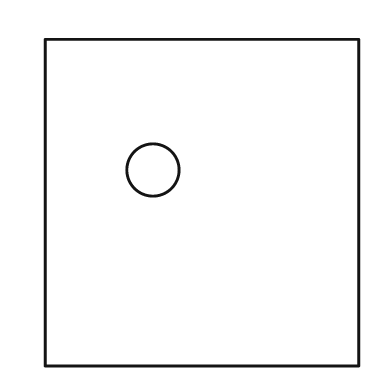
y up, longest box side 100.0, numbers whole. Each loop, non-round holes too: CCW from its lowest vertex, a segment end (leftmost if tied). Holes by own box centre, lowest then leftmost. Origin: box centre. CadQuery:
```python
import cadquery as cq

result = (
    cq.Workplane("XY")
    .moveTo(-48.0, -50.0)
    .lineTo(48.0, -50.0)
    .lineTo(48.0, 50.0)
    .lineTo(-48.0, 50.0)
    .close()
    .moveTo(-15.0, 10.0)
    .circle(8.0)
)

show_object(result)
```